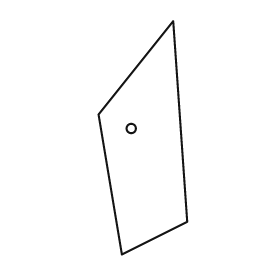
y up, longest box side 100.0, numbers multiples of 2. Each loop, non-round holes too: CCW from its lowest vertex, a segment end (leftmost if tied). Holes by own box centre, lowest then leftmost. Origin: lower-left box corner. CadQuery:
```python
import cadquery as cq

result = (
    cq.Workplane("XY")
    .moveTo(10.0, 0.0)
    .lineTo(38.0, 14.0)
    .lineTo(32.0, 100.0)
    .lineTo(0.0, 60.0)
    .close()
    .moveTo(14.0, 54.0)
    .circle(2.0)
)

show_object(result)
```